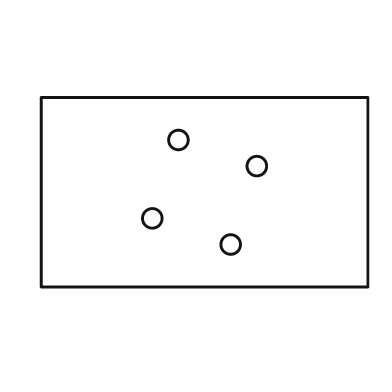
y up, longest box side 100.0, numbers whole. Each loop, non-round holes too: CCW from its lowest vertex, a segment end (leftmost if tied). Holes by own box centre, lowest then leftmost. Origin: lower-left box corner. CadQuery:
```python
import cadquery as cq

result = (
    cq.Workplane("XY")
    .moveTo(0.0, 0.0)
    .lineTo(100.0, 0.0)
    .lineTo(100.0, 58.0)
    .lineTo(0.0, 58.0)
    .close()
    .moveTo(58.0, 13.0)
    .circle(3.0)
    .moveTo(34.0, 21.0)
    .circle(3.0)
    .moveTo(66.0, 37.0)
    .circle(3.0)
    .moveTo(42.0, 45.0)
    .circle(3.0)
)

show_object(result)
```